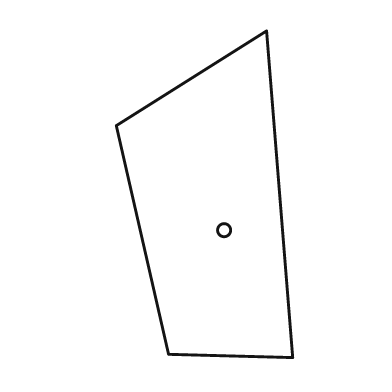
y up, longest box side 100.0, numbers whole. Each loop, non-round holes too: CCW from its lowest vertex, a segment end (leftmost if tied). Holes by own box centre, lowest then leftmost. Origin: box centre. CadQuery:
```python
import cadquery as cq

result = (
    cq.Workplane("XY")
    .moveTo(27.0, -50.0)
    .lineTo(19.0, 50.0)
    .lineTo(-27.0, 21.0)
    .lineTo(-11.0, -49.0)
    .close()
    .moveTo(6.0, -11.0)
    .circle(2.0)
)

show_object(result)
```